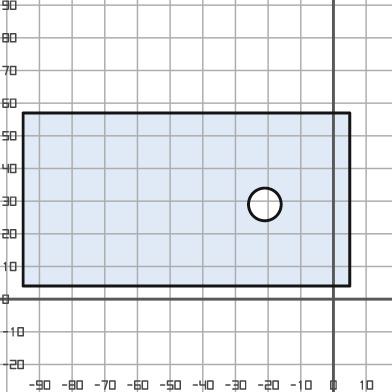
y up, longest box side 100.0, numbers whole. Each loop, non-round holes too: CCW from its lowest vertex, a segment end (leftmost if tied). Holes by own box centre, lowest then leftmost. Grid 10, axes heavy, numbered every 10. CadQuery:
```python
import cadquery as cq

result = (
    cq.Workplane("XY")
    .moveTo(-95.0, 4.0)
    .lineTo(5.0, 4.0)
    .lineTo(5.0, 57.0)
    .lineTo(-95.0, 57.0)
    .close()
    .moveTo(-21.0, 29.0)
    .circle(5.0)
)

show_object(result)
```